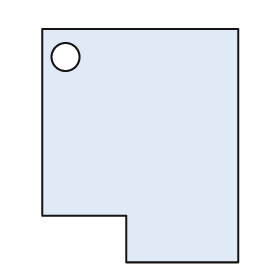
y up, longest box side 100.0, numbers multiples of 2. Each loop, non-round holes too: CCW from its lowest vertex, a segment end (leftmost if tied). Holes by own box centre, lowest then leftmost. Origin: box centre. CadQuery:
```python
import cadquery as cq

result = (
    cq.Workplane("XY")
    .moveTo(-6.0, -50.0)
    .lineTo(42.0, -50.0)
    .lineTo(42.0, 50.0)
    .lineTo(-42.0, 50.0)
    .lineTo(-42.0, -30.0)
    .lineTo(-6.0, -30.0)
    .close()
    .moveTo(-32.0, 38.0)
    .circle(6.0)
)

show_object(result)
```